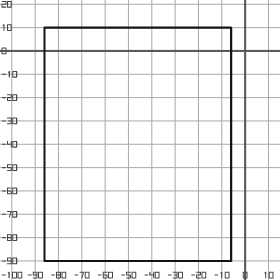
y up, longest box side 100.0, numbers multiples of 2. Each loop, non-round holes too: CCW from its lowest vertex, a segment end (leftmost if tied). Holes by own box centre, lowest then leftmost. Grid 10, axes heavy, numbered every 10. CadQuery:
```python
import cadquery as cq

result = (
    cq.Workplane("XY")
    .moveTo(-86.0, -90.0)
    .lineTo(-6.0, -90.0)
    .lineTo(-6.0, 10.0)
    .lineTo(-86.0, 10.0)
    .close()
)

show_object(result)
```